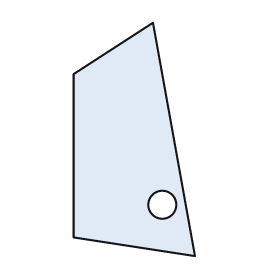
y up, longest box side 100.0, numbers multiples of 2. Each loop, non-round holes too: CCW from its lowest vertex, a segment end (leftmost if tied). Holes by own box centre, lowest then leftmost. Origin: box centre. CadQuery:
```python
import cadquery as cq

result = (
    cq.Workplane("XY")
    .moveTo(26.0, -50.0)
    .lineTo(8.0, 50.0)
    .lineTo(-26.0, 28.0)
    .lineTo(-26.0, -42.0)
    .close()
    .moveTo(12.0, -28.0)
    .circle(6.0)
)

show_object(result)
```